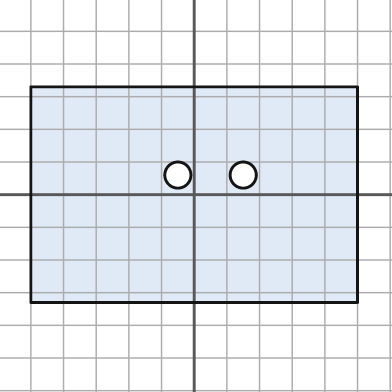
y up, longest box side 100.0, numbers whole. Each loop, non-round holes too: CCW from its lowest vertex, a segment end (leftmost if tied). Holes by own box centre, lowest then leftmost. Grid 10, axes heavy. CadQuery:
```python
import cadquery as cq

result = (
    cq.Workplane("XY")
    .moveTo(-50.0, -33.0)
    .lineTo(50.0, -33.0)
    .lineTo(50.0, 33.0)
    .lineTo(-50.0, 33.0)
    .close()
    .moveTo(-5.0, 6.0)
    .circle(4.0)
    .moveTo(15.0, 6.0)
    .circle(4.0)
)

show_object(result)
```